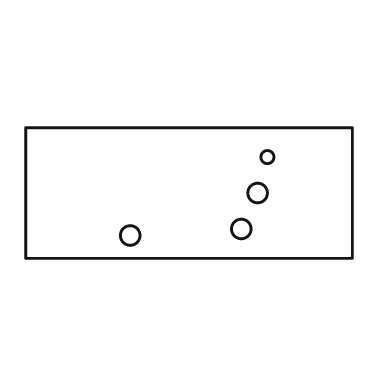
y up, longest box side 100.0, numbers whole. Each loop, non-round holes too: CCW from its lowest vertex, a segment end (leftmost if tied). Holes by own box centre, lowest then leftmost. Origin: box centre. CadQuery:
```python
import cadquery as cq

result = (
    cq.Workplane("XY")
    .moveTo(-50.0, -20.0)
    .lineTo(50.0, -20.0)
    .lineTo(50.0, 20.0)
    .lineTo(-50.0, 20.0)
    .close()
    .moveTo(-18.0, -13.0)
    .circle(3.0)
    .moveTo(16.0, -11.0)
    .circle(3.0)
    .moveTo(21.0, 0.0)
    .circle(3.0)
    .moveTo(24.0, 11.0)
    .circle(2.0)
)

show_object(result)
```